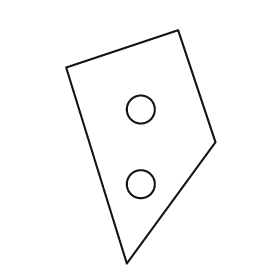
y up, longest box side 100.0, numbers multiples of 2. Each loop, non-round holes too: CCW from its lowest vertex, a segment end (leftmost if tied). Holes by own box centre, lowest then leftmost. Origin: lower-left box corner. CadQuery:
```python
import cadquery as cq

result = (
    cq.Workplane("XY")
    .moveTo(26.0, 0.0)
    .lineTo(64.0, 52.0)
    .lineTo(48.0, 100.0)
    .lineTo(0.0, 84.0)
    .close()
    .moveTo(32.0, 34.0)
    .circle(6.0)
    .moveTo(32.0, 66.0)
    .circle(6.0)
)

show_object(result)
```